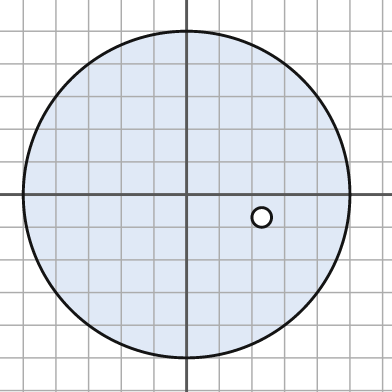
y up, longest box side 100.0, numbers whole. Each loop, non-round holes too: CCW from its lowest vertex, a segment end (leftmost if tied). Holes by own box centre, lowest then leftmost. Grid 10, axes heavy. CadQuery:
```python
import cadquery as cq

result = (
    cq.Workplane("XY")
    .moveTo(0.0, 0.0)
    .circle(50.0)
    .moveTo(23.0, -7.0)
    .circle(3.0)
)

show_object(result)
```